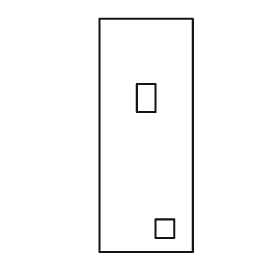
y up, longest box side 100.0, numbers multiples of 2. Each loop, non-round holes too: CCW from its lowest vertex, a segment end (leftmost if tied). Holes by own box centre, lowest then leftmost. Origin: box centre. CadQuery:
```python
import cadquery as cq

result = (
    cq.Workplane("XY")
    .moveTo(-20.0, -50.0)
    .lineTo(20.0, -50.0)
    .lineTo(20.0, 50.0)
    .lineTo(-20.0, 50.0)
    .close()
    .moveTo(4.0, -44.0)
    .lineTo(12.0, -44.0)
    .lineTo(12.0, -36.0)
    .lineTo(4.0, -36.0)
    .close()
    .moveTo(-4.0, 10.0)
    .lineTo(4.0, 10.0)
    .lineTo(4.0, 22.0)
    .lineTo(-4.0, 22.0)
    .close()
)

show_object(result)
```